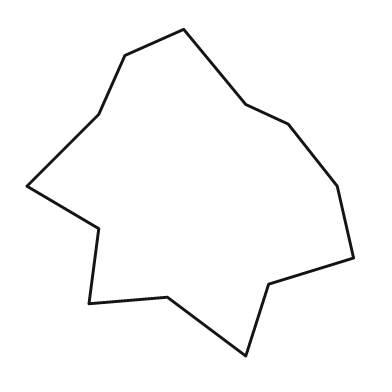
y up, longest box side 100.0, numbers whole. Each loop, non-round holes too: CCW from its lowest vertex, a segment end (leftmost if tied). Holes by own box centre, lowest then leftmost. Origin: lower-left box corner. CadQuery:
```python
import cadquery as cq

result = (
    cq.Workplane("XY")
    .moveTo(67.0, 0.0)
    .lineTo(74.0, 22.0)
    .lineTo(100.0, 30.0)
    .lineTo(95.0, 52.0)
    .lineTo(80.0, 71.0)
    .lineTo(67.0, 77.0)
    .lineTo(48.0, 100.0)
    .lineTo(30.0, 92.0)
    .lineTo(22.0, 74.0)
    .lineTo(0.0, 52.0)
    .lineTo(22.0, 39.0)
    .lineTo(19.0, 16.0)
    .lineTo(43.0, 18.0)
    .close()
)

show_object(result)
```